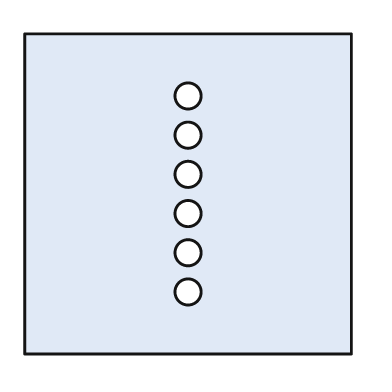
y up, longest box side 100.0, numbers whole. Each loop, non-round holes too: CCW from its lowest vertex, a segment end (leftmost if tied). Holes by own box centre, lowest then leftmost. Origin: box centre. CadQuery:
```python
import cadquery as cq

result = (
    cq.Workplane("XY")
    .moveTo(-50.0, -49.0)
    .lineTo(50.0, -49.0)
    .lineTo(50.0, 49.0)
    .lineTo(-50.0, 49.0)
    .close()
    .moveTo(0.0, -30.0)
    .circle(4.0)
    .moveTo(0.0, -18.0)
    .circle(4.0)
    .moveTo(0.0, -6.0)
    .circle(4.0)
    .moveTo(0.0, 6.0)
    .circle(4.0)
    .moveTo(0.0, 18.0)
    .circle(4.0)
    .moveTo(0.0, 30.0)
    .circle(4.0)
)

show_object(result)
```